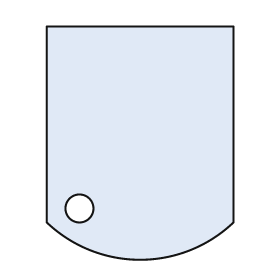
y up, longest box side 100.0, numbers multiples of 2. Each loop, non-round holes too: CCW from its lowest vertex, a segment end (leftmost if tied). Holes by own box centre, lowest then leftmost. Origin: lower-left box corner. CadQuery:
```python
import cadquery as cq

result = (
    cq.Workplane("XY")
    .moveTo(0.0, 16.0)
    .threePointArc((40.0, 0.0), (80.0, 16.0))
    .lineTo(80.0, 100.0)
    .lineTo(0.0, 100.0)
    .close()
    .moveTo(14.0, 22.0)
    .circle(6.0)
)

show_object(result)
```